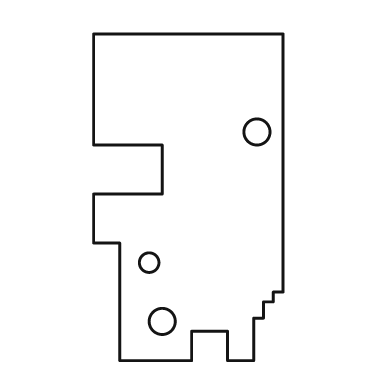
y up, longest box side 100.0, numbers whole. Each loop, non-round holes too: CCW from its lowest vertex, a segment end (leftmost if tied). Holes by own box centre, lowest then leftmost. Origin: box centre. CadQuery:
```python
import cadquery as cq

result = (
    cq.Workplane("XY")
    .moveTo(-21.0, -50.0)
    .lineTo(1.0, -50.0)
    .lineTo(1.0, -41.0)
    .lineTo(12.0, -41.0)
    .lineTo(12.0, -50.0)
    .lineTo(20.0, -50.0)
    .lineTo(20.0, -37.0)
    .lineTo(23.0, -37.0)
    .lineTo(23.0, -32.0)
    .lineTo(26.0, -32.0)
    .lineTo(26.0, -29.0)
    .lineTo(29.0, -29.0)
    .lineTo(29.0, 50.0)
    .lineTo(-29.0, 50.0)
    .lineTo(-29.0, 16.0)
    .lineTo(-8.0, 16.0)
    .lineTo(-8.0, 1.0)
    .lineTo(-29.0, 1.0)
    .lineTo(-29.0, -14.0)
    .lineTo(-21.0, -14.0)
    .close()
    .moveTo(-8.0, -38.0)
    .circle(4.0)
    .moveTo(-12.0, -20.0)
    .circle(3.0)
    .moveTo(21.0, 20.0)
    .circle(4.0)
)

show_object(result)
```